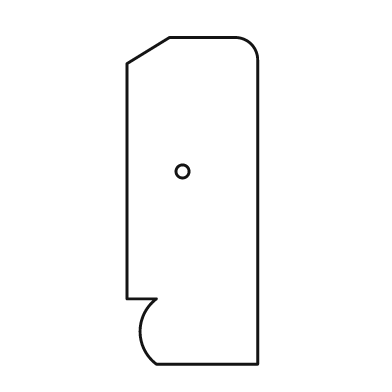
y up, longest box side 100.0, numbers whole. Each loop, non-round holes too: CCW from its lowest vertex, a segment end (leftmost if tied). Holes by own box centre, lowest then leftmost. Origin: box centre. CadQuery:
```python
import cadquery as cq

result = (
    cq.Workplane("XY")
    .moveTo(-11.0, -50.0)
    .lineTo(20.0, -50.0)
    .lineTo(20.0, 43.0)
    .threePointArc((18.0, 48.0), (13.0, 50.0))
    .lineTo(-7.0, 50.0)
    .lineTo(-20.0, 42.0)
    .lineTo(-20.0, -30.0)
    .lineTo(-11.0, -30.0)
    .threePointArc((-16.0, -40.0), (-11.0, -50.0))
    .close()
    .moveTo(-3.0, 9.0)
    .circle(2.0)
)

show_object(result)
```